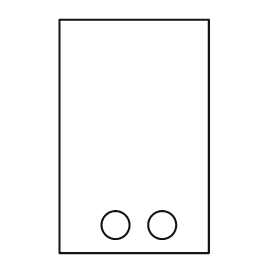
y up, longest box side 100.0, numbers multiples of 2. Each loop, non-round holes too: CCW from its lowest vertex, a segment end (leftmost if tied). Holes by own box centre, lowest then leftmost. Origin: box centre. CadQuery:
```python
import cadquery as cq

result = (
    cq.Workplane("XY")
    .moveTo(-32.0, -50.0)
    .lineTo(32.0, -50.0)
    .lineTo(32.0, 50.0)
    .lineTo(-32.0, 50.0)
    .close()
    .moveTo(-8.0, -38.0)
    .circle(6.0)
    .moveTo(12.0, -38.0)
    .circle(6.0)
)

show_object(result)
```